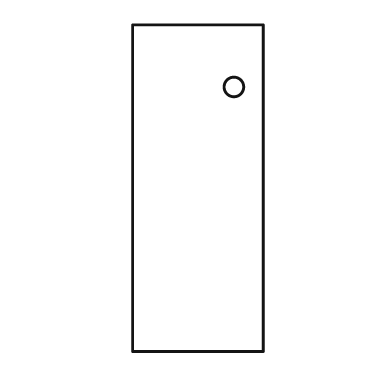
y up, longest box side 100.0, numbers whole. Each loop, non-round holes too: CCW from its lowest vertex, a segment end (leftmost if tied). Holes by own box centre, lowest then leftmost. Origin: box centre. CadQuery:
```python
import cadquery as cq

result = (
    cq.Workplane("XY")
    .moveTo(-20.0, -50.0)
    .lineTo(20.0, -50.0)
    .lineTo(20.0, 50.0)
    .lineTo(-20.0, 50.0)
    .close()
    .moveTo(11.0, 31.0)
    .circle(3.0)
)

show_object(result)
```